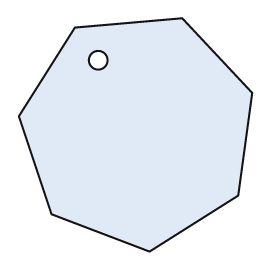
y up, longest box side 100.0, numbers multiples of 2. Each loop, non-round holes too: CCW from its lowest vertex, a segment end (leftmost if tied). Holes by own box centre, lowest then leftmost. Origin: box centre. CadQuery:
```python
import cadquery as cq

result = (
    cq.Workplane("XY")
    .moveTo(6.0, -50.0)
    .lineTo(44.0, -26.0)
    .lineTo(50.0, 18.0)
    .lineTo(20.0, 50.0)
    .lineTo(-26.0, 46.0)
    .lineTo(-50.0, 8.0)
    .lineTo(-36.0, -34.0)
    .close()
    .moveTo(-16.0, 32.0)
    .circle(4.0)
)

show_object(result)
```